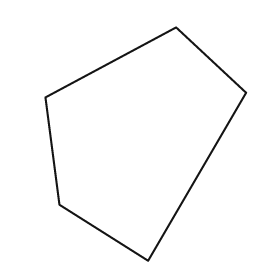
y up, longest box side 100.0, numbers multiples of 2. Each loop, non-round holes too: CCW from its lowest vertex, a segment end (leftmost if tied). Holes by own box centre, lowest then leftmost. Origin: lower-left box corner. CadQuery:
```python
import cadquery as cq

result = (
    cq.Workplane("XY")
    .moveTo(44.0, 0.0)
    .lineTo(86.0, 72.0)
    .lineTo(56.0, 100.0)
    .lineTo(0.0, 70.0)
    .lineTo(6.0, 24.0)
    .close()
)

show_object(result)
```